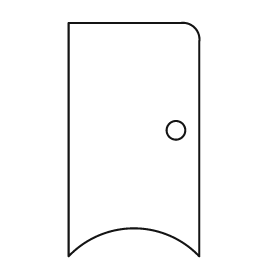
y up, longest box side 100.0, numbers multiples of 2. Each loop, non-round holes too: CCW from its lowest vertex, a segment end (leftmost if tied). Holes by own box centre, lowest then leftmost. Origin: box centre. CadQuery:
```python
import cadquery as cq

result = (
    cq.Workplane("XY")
    .moveTo(-28.0, -50.0)
    .threePointArc((0.0, -38.0), (28.0, -50.0))
    .lineTo(28.0, 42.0)
    .threePointArc((26.0, 48.0), (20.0, 50.0))
    .lineTo(-28.0, 50.0)
    .close()
    .moveTo(18.0, 4.0)
    .circle(4.0)
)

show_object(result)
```